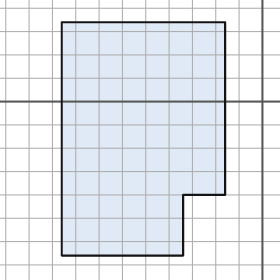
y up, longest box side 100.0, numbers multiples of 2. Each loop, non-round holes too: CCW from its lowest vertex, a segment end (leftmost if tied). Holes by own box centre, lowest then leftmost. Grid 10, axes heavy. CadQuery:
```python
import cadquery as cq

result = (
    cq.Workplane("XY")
    .moveTo(-86.0, -66.0)
    .lineTo(-34.0, -66.0)
    .lineTo(-34.0, -40.0)
    .lineTo(-16.0, -40.0)
    .lineTo(-16.0, 34.0)
    .lineTo(-86.0, 34.0)
    .close()
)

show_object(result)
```